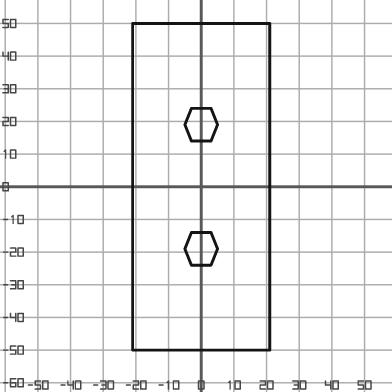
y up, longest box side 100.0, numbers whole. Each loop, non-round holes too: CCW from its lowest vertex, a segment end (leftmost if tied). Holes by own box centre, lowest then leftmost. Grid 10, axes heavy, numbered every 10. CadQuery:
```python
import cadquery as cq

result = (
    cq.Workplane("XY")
    .moveTo(-21.0, -50.0)
    .lineTo(21.0, -50.0)
    .lineTo(21.0, 50.0)
    .lineTo(-21.0, 50.0)
    .close()
    .moveTo(-3.0, -24.0)
    .lineTo(3.0, -24.0)
    .lineTo(5.0, -19.0)
    .lineTo(3.0, -14.0)
    .lineTo(-3.0, -14.0)
    .lineTo(-5.0, -19.0)
    .close()
    .moveTo(-3.0, 14.0)
    .lineTo(3.0, 14.0)
    .lineTo(5.0, 19.0)
    .lineTo(3.0, 24.0)
    .lineTo(-3.0, 24.0)
    .lineTo(-5.0, 19.0)
    .close()
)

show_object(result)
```